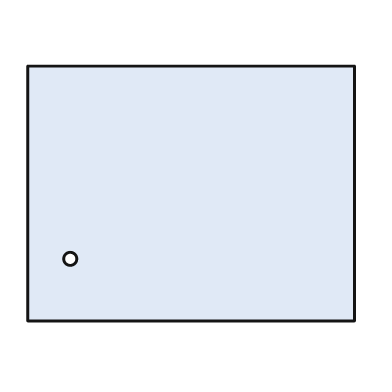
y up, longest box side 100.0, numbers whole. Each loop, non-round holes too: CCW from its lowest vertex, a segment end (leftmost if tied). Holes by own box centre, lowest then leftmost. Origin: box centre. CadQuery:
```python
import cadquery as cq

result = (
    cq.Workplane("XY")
    .moveTo(-50.0, -39.0)
    .lineTo(50.0, -39.0)
    .lineTo(50.0, 39.0)
    .lineTo(-50.0, 39.0)
    .close()
    .moveTo(-37.0, -20.0)
    .circle(2.0)
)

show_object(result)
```